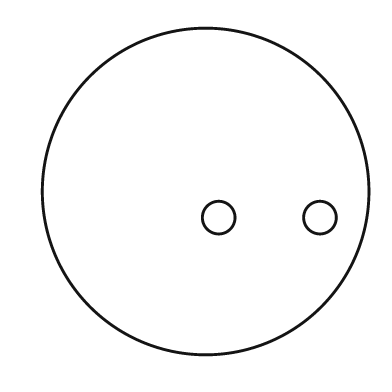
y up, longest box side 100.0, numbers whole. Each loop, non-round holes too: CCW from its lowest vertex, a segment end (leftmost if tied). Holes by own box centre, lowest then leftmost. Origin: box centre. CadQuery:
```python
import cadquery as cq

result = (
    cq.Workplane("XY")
    .moveTo(0.0, 0.0)
    .circle(50.0)
    .moveTo(4.0, -8.0)
    .circle(5.0)
    .moveTo(35.0, -8.0)
    .circle(5.0)
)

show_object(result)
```